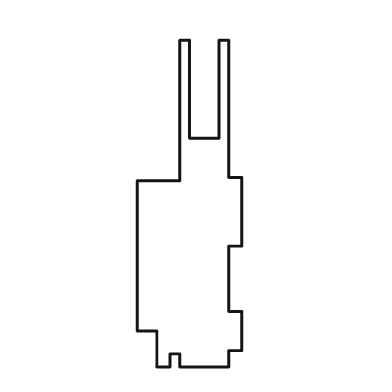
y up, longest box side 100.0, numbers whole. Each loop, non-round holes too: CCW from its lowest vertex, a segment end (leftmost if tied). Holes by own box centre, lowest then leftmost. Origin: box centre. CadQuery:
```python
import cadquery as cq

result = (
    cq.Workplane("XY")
    .moveTo(-10.0, -50.0)
    .lineTo(-6.0, -50.0)
    .lineTo(-6.0, -46.0)
    .lineTo(-3.0, -46.0)
    .lineTo(-3.0, -50.0)
    .lineTo(12.0, -50.0)
    .lineTo(12.0, -45.0)
    .lineTo(16.0, -45.0)
    .lineTo(16.0, -33.0)
    .lineTo(12.0, -33.0)
    .lineTo(12.0, -13.0)
    .lineTo(16.0, -13.0)
    .lineTo(16.0, 8.0)
    .lineTo(12.0, 8.0)
    .lineTo(12.0, 50.0)
    .lineTo(9.0, 50.0)
    .lineTo(9.0, 20.0)
    .lineTo(0.0, 20.0)
    .lineTo(0.0, 50.0)
    .lineTo(-3.0, 50.0)
    .lineTo(-3.0, 7.0)
    .lineTo(-16.0, 7.0)
    .lineTo(-16.0, -39.0)
    .lineTo(-10.0, -39.0)
    .close()
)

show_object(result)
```